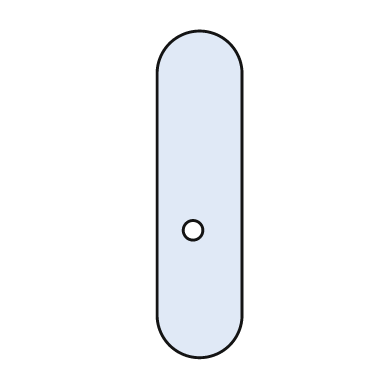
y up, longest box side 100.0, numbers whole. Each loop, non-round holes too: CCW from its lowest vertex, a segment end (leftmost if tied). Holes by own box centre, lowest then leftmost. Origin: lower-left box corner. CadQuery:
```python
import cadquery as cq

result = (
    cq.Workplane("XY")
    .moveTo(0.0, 13.0)
    .threePointArc((13.0, 0.0), (26.0, 13.0))
    .lineTo(26.0, 87.0)
    .threePointArc((13.0, 100.0), (0.0, 87.0))
    .close()
    .moveTo(11.0, 39.0)
    .circle(3.0)
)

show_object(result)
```